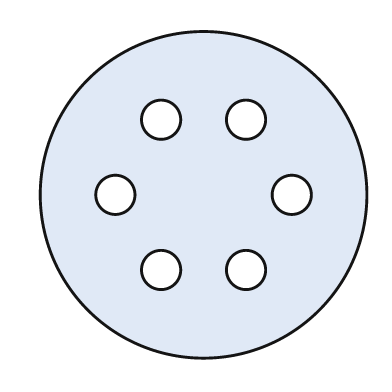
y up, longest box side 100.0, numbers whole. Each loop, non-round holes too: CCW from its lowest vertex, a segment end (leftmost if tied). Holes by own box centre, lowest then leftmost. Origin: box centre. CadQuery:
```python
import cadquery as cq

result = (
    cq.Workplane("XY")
    .moveTo(0.0, 0.0)
    .circle(50.0)
    .moveTo(-13.0, -23.0)
    .circle(6.0)
    .moveTo(13.0, -23.0)
    .circle(6.0)
    .moveTo(-27.0, 0.0)
    .circle(6.0)
    .moveTo(27.0, 0.0)
    .circle(6.0)
    .moveTo(-13.0, 23.0)
    .circle(6.0)
    .moveTo(13.0, 23.0)
    .circle(6.0)
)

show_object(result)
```